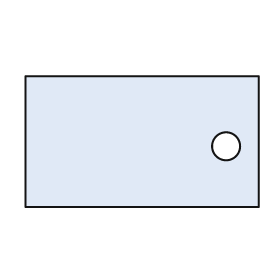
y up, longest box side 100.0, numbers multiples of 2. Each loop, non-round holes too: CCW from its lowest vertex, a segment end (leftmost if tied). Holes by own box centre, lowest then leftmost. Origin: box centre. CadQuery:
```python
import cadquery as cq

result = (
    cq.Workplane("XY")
    .moveTo(-50.0, -28.0)
    .lineTo(50.0, -28.0)
    .lineTo(50.0, 28.0)
    .lineTo(-50.0, 28.0)
    .close()
    .moveTo(36.0, -2.0)
    .circle(6.0)
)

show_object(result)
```